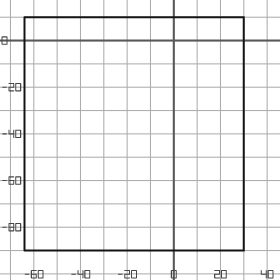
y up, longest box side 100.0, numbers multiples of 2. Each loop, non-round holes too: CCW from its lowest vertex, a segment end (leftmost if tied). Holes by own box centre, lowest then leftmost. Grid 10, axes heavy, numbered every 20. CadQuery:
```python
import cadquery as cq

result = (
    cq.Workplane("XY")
    .moveTo(-64.0, -90.0)
    .lineTo(30.0, -90.0)
    .lineTo(30.0, 10.0)
    .lineTo(-64.0, 10.0)
    .close()
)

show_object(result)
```